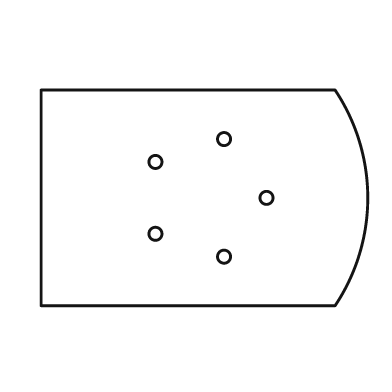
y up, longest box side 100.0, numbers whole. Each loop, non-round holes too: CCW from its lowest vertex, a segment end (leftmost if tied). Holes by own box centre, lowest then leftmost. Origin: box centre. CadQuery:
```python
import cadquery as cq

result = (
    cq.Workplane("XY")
    .moveTo(-50.0, -33.0)
    .lineTo(40.0, -33.0)
    .threePointArc((50.0, 0.0), (40.0, 33.0))
    .lineTo(-50.0, 33.0)
    .close()
    .moveTo(6.0, -18.0)
    .circle(2.0)
    .moveTo(-15.0, -11.0)
    .circle(2.0)
    .moveTo(19.0, 0.0)
    .circle(2.0)
    .moveTo(-15.0, 11.0)
    .circle(2.0)
    .moveTo(6.0, 18.0)
    .circle(2.0)
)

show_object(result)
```